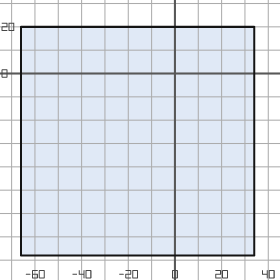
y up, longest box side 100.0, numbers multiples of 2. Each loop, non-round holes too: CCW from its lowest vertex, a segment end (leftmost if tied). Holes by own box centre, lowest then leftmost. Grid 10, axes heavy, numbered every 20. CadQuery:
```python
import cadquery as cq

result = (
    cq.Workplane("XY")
    .moveTo(-66.0, -78.0)
    .lineTo(34.0, -78.0)
    .lineTo(34.0, 20.0)
    .lineTo(-66.0, 20.0)
    .close()
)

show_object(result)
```